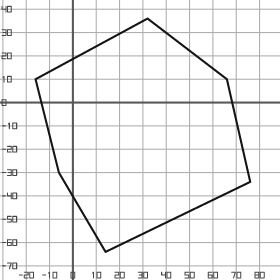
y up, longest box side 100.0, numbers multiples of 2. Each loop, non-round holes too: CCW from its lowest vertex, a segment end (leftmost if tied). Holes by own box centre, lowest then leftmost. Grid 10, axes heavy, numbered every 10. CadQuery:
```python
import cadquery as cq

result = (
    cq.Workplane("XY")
    .moveTo(14.0, -64.0)
    .lineTo(76.0, -34.0)
    .lineTo(66.0, 10.0)
    .lineTo(32.0, 36.0)
    .lineTo(-16.0, 10.0)
    .lineTo(-6.0, -30.0)
    .close()
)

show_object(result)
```